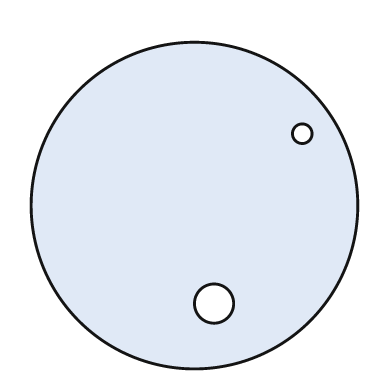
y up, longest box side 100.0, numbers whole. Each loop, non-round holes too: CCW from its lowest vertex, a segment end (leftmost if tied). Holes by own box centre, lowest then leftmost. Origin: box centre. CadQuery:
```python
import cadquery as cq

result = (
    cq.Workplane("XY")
    .moveTo(0.0, 0.0)
    .circle(50.0)
    .moveTo(6.0, -30.0)
    .circle(6.0)
    .moveTo(33.0, 22.0)
    .circle(3.0)
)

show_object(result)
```